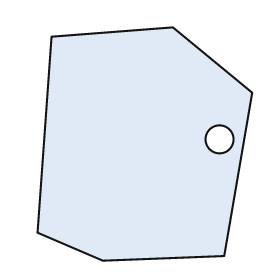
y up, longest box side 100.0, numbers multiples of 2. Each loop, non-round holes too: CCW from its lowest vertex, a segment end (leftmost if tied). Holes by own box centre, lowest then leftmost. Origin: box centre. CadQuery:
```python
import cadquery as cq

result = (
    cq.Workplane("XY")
    .moveTo(-18.0, -50.0)
    .lineTo(34.0, -48.0)
    .lineTo(46.0, 22.0)
    .lineTo(12.0, 50.0)
    .lineTo(-40.0, 46.0)
    .lineTo(-46.0, -38.0)
    .close()
    .moveTo(32.0, 2.0)
    .circle(6.0)
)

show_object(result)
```